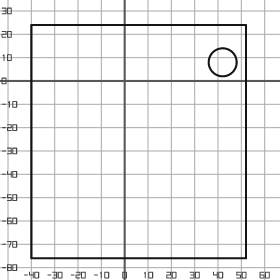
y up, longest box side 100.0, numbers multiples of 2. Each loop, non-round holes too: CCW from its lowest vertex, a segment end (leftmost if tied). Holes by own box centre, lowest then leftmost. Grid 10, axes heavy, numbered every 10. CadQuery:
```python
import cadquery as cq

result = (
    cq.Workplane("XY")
    .moveTo(-40.0, -76.0)
    .lineTo(52.0, -76.0)
    .lineTo(52.0, 24.0)
    .lineTo(-40.0, 24.0)
    .close()
    .moveTo(42.0, 8.0)
    .circle(6.0)
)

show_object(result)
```